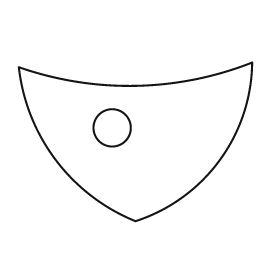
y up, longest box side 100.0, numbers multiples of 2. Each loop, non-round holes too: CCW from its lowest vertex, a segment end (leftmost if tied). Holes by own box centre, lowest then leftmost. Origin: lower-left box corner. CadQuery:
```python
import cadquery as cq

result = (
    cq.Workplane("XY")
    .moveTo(50.0, 0.0)
    .threePointArc((86.0, 26.0), (100.0, 68.0))
    .threePointArc((50.0, 58.0), (0.0, 66.0))
    .threePointArc((16.0, 26.0), (50.0, 0.0))
    .close()
    .moveTo(40.0, 40.0)
    .circle(8.0)
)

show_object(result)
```